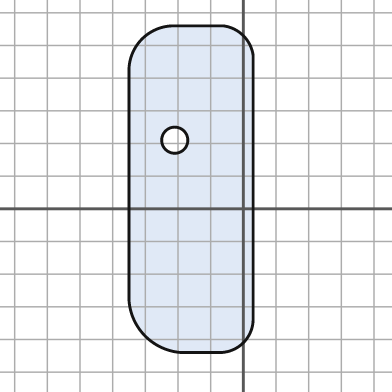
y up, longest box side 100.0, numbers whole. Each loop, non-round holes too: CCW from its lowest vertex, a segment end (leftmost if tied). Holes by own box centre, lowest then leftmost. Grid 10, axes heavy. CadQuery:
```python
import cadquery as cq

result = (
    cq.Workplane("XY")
    .moveTo(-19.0, -44.0)
    .lineTo(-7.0, -44.0)
    .threePointArc((0.0, -41.0), (3.0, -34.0))
    .lineTo(3.0, 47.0)
    .threePointArc((0.0, 53.0), (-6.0, 56.0))
    .lineTo(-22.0, 56.0)
    .threePointArc((-31.0, 52.0), (-35.0, 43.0))
    .lineTo(-35.0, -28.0)
    .threePointArc((-30.0, -39.0), (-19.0, -44.0))
    .close()
    .moveTo(-21.0, 21.0)
    .circle(4.0)
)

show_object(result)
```